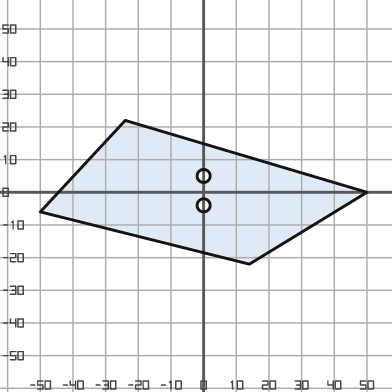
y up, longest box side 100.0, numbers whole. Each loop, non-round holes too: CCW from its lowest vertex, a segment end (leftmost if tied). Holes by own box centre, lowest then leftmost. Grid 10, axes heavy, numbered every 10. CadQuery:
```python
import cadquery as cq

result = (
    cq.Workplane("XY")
    .moveTo(14.0, -22.0)
    .lineTo(50.0, 0.0)
    .lineTo(-24.0, 22.0)
    .lineTo(-50.0, -6.0)
    .close()
    .moveTo(0.0, -4.0)
    .circle(2.0)
    .moveTo(0.0, 5.0)
    .circle(2.0)
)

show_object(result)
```